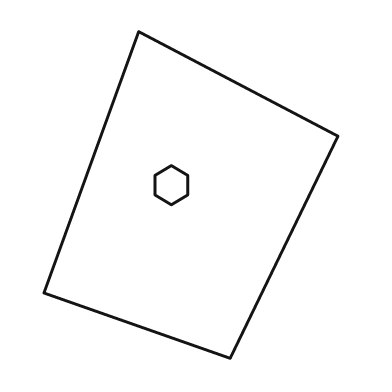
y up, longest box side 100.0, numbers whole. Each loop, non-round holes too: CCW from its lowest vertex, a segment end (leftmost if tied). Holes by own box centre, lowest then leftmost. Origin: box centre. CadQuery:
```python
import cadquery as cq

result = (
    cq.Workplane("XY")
    .moveTo(12.0, -50.0)
    .lineTo(45.0, 18.0)
    .lineTo(-16.0, 50.0)
    .lineTo(-45.0, -30.0)
    .close()
    .moveTo(-6.0, -3.0)
    .lineTo(-1.0, 0.0)
    .lineTo(-1.0, 6.0)
    .lineTo(-6.0, 9.0)
    .lineTo(-11.0, 6.0)
    .lineTo(-11.0, 0.0)
    .close()
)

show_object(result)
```